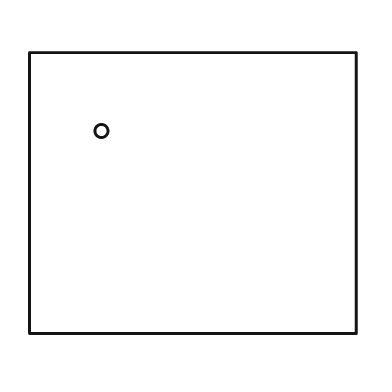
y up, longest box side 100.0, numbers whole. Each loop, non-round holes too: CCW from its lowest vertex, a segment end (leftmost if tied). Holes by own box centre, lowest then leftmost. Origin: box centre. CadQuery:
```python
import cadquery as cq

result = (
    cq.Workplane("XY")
    .moveTo(-50.0, -43.0)
    .lineTo(50.0, -43.0)
    .lineTo(50.0, 43.0)
    .lineTo(-50.0, 43.0)
    .close()
    .moveTo(-28.0, 19.0)
    .circle(2.0)
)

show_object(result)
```